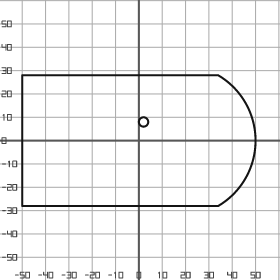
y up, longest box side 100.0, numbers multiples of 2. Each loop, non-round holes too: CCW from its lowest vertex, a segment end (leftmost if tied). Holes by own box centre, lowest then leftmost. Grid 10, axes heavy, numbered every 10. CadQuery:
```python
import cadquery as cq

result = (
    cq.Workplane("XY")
    .moveTo(-50.0, -28.0)
    .lineTo(34.0, -28.0)
    .threePointArc((50.0, 0.0), (34.0, 28.0))
    .lineTo(-50.0, 28.0)
    .close()
    .moveTo(2.0, 8.0)
    .circle(2.0)
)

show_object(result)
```